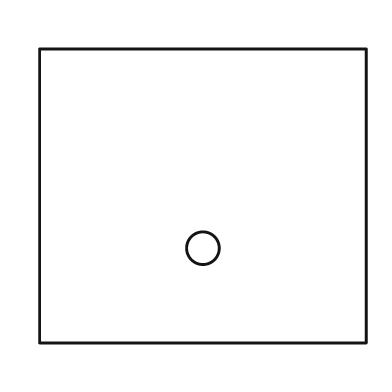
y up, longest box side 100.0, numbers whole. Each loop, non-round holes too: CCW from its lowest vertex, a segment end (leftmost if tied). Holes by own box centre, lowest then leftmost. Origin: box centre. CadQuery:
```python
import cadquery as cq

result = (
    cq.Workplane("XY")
    .moveTo(-50.0, -45.0)
    .lineTo(50.0, -45.0)
    .lineTo(50.0, 45.0)
    .lineTo(-50.0, 45.0)
    .close()
    .moveTo(0.0, -16.0)
    .circle(5.0)
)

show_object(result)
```